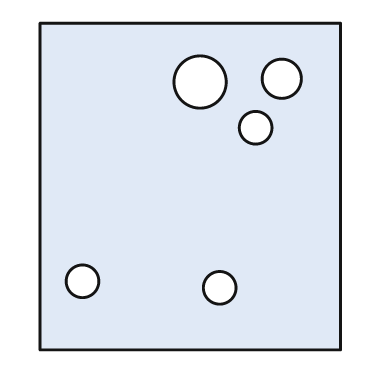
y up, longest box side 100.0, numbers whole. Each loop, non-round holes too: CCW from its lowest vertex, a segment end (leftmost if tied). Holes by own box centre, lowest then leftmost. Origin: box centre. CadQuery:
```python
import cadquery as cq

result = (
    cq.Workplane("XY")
    .moveTo(-46.0, -50.0)
    .lineTo(46.0, -50.0)
    .lineTo(46.0, 50.0)
    .lineTo(-46.0, 50.0)
    .close()
    .moveTo(9.0, -31.0)
    .circle(5.0)
    .moveTo(-33.0, -29.0)
    .circle(5.0)
    .moveTo(20.0, 18.0)
    .circle(5.0)
    .moveTo(3.0, 32.0)
    .circle(8.0)
    .moveTo(28.0, 33.0)
    .circle(6.0)
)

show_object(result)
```